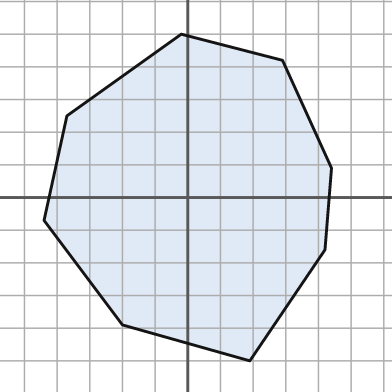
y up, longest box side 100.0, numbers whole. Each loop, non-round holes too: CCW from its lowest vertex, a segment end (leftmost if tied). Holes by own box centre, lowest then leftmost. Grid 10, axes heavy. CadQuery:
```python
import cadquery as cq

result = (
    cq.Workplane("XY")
    .moveTo(19.0, -50.0)
    .lineTo(42.0, -16.0)
    .lineTo(44.0, 9.0)
    .lineTo(29.0, 42.0)
    .lineTo(-2.0, 50.0)
    .lineTo(-37.0, 25.0)
    .lineTo(-44.0, -7.0)
    .lineTo(-20.0, -39.0)
    .close()
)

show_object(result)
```